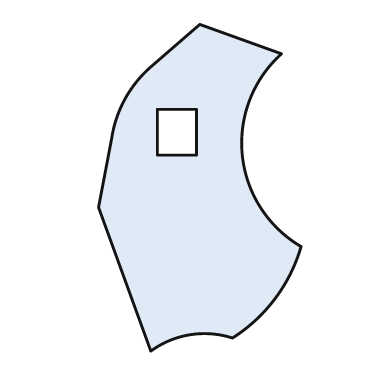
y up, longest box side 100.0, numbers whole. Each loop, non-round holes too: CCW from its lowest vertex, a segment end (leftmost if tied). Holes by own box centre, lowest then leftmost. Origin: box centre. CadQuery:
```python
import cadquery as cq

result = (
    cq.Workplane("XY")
    .moveTo(-15.0, -50.0)
    .threePointArc((-3.0, -45.0), (10.0, -46.0))
    .threePointArc((23.0, -34.0), (31.0, -18.0))
    .threePointArc((13.0, 10.0), (25.0, 41.0))
    .lineTo(0.0, 50.0)
    .lineTo(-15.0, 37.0)
    .threePointArc((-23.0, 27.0), (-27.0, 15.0))
    .lineTo(-31.0, -6.0)
    .close()
    .moveTo(-13.0, 10.0)
    .lineTo(-1.0, 10.0)
    .lineTo(-1.0, 24.0)
    .lineTo(-13.0, 24.0)
    .close()
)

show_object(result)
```